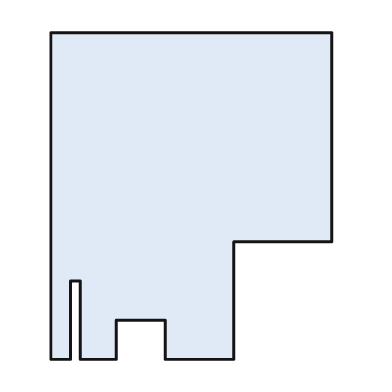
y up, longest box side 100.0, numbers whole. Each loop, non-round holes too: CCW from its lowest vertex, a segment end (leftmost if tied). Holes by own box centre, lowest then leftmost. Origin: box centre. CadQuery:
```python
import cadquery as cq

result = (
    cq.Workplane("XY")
    .moveTo(-43.0, -50.0)
    .lineTo(-37.0, -50.0)
    .lineTo(-37.0, -26.0)
    .lineTo(-34.0, -26.0)
    .lineTo(-34.0, -50.0)
    .lineTo(-23.0, -50.0)
    .lineTo(-23.0, -38.0)
    .lineTo(-8.0, -38.0)
    .lineTo(-8.0, -50.0)
    .lineTo(13.0, -50.0)
    .lineTo(13.0, -14.0)
    .lineTo(43.0, -14.0)
    .lineTo(43.0, 50.0)
    .lineTo(-43.0, 50.0)
    .close()
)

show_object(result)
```